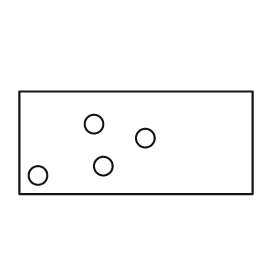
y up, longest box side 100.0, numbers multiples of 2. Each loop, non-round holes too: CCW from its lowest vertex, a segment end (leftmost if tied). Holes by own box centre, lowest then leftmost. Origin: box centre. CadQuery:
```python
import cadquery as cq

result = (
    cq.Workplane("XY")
    .moveTo(-50.0, -22.0)
    .lineTo(50.0, -22.0)
    .lineTo(50.0, 22.0)
    .lineTo(-50.0, 22.0)
    .close()
    .moveTo(-42.0, -14.0)
    .circle(4.0)
    .moveTo(-14.0, -10.0)
    .circle(4.0)
    .moveTo(4.0, 2.0)
    .circle(4.0)
    .moveTo(-18.0, 8.0)
    .circle(4.0)
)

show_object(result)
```